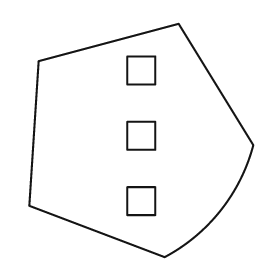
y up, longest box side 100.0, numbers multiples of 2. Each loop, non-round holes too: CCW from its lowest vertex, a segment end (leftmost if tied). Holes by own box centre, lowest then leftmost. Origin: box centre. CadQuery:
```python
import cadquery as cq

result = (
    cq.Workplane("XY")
    .moveTo(10.0, -50.0)
    .threePointArc((34.0, -30.0), (48.0, -2.0))
    .lineTo(16.0, 50.0)
    .lineTo(-44.0, 34.0)
    .lineTo(-48.0, -28.0)
    .close()
    .moveTo(-6.0, -32.0)
    .lineTo(6.0, -32.0)
    .lineTo(6.0, -20.0)
    .lineTo(-6.0, -20.0)
    .close()
    .moveTo(-6.0, -4.0)
    .lineTo(6.0, -4.0)
    .lineTo(6.0, 8.0)
    .lineTo(-6.0, 8.0)
    .close()
    .moveTo(-6.0, 24.0)
    .lineTo(6.0, 24.0)
    .lineTo(6.0, 36.0)
    .lineTo(-6.0, 36.0)
    .close()
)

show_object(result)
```